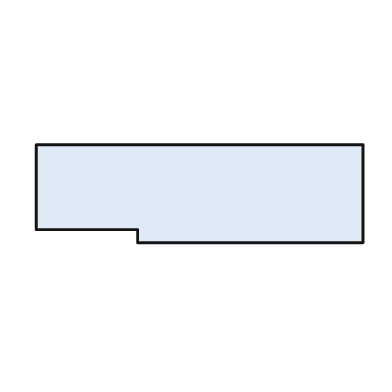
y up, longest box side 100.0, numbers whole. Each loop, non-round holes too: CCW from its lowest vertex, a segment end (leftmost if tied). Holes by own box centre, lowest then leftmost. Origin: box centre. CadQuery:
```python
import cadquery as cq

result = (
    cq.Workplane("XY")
    .moveTo(-19.0, -15.0)
    .lineTo(50.0, -15.0)
    .lineTo(50.0, 15.0)
    .lineTo(-50.0, 15.0)
    .lineTo(-50.0, -11.0)
    .lineTo(-19.0, -11.0)
    .close()
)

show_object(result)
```